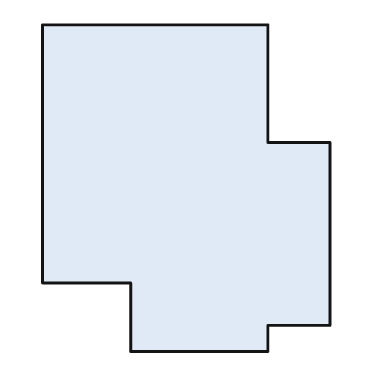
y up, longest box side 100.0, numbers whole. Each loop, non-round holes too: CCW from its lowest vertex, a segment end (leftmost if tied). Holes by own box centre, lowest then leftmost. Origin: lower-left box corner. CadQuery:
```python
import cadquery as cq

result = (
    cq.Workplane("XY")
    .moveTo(27.0, 0.0)
    .lineTo(69.0, 0.0)
    .lineTo(69.0, 8.0)
    .lineTo(88.0, 8.0)
    .lineTo(88.0, 64.0)
    .lineTo(69.0, 64.0)
    .lineTo(69.0, 100.0)
    .lineTo(0.0, 100.0)
    .lineTo(0.0, 21.0)
    .lineTo(27.0, 21.0)
    .close()
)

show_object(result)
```